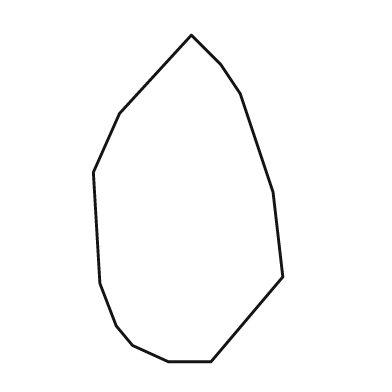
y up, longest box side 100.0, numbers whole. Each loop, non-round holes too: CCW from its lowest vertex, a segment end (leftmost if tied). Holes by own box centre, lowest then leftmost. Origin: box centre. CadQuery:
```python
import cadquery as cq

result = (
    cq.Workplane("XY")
    .moveTo(-6.0, -50.0)
    .lineTo(7.0, -50.0)
    .lineTo(29.0, -24.0)
    .lineTo(26.0, 2.0)
    .lineTo(16.0, 32.0)
    .lineTo(10.0, 41.0)
    .lineTo(1.0, 50.0)
    .lineTo(-21.0, 26.0)
    .lineTo(-29.0, 8.0)
    .lineTo(-27.0, -26.0)
    .lineTo(-22.0, -39.0)
    .lineTo(-17.0, -45.0)
    .close()
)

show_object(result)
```